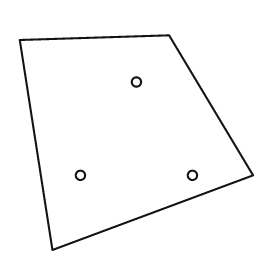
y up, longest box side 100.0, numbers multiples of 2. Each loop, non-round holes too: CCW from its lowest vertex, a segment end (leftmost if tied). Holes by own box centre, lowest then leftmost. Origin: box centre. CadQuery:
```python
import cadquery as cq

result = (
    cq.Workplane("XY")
    .moveTo(-36.0, -46.0)
    .lineTo(50.0, -14.0)
    .lineTo(14.0, 46.0)
    .lineTo(-50.0, 44.0)
    .close()
    .moveTo(-24.0, -14.0)
    .circle(2.0)
    .moveTo(24.0, -14.0)
    .circle(2.0)
    .moveTo(0.0, 26.0)
    .circle(2.0)
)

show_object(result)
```